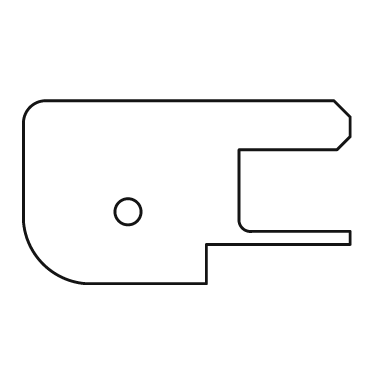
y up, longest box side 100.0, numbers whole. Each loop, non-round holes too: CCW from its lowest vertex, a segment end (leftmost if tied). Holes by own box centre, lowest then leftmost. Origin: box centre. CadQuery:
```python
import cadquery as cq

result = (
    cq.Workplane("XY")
    .moveTo(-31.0, -28.0)
    .lineTo(6.0, -28.0)
    .lineTo(6.0, -16.0)
    .lineTo(50.0, -16.0)
    .lineTo(50.0, -12.0)
    .lineTo(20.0, -12.0)
    .threePointArc((17.0, -11.0), (16.0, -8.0))
    .lineTo(16.0, 13.0)
    .lineTo(46.0, 13.0)
    .lineTo(50.0, 17.0)
    .lineTo(50.0, 23.0)
    .lineTo(45.0, 28.0)
    .lineTo(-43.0, 28.0)
    .threePointArc((-48.0, 26.0), (-50.0, 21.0))
    .lineTo(-50.0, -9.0)
    .threePointArc((-44.0, -22.0), (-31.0, -28.0))
    .close()
    .moveTo(-18.0, -6.0)
    .circle(4.0)
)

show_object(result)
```